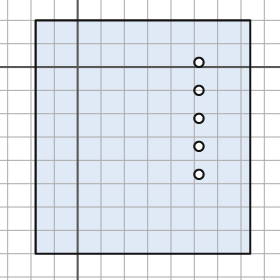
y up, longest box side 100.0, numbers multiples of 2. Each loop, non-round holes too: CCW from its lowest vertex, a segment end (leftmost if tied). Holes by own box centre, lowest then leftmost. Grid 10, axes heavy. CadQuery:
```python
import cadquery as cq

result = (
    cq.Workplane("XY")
    .moveTo(-18.0, -80.0)
    .lineTo(74.0, -80.0)
    .lineTo(74.0, 20.0)
    .lineTo(-18.0, 20.0)
    .close()
    .moveTo(52.0, -46.0)
    .circle(2.0)
    .moveTo(52.0, -34.0)
    .circle(2.0)
    .moveTo(52.0, -22.0)
    .circle(2.0)
    .moveTo(52.0, -10.0)
    .circle(2.0)
    .moveTo(52.0, 2.0)
    .circle(2.0)
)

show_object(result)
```